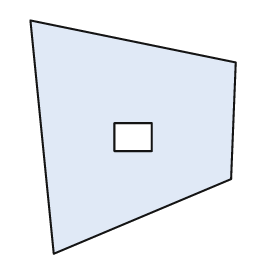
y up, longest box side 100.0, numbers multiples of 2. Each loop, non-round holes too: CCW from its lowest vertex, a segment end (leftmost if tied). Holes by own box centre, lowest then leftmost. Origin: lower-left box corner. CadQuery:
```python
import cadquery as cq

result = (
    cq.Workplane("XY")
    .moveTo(10.0, 0.0)
    .lineTo(86.0, 32.0)
    .lineTo(88.0, 82.0)
    .lineTo(0.0, 100.0)
    .close()
    .moveTo(36.0, 44.0)
    .lineTo(52.0, 44.0)
    .lineTo(52.0, 56.0)
    .lineTo(36.0, 56.0)
    .close()
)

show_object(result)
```